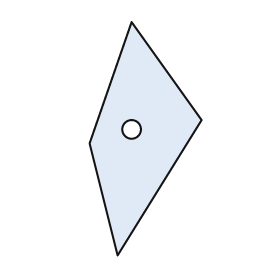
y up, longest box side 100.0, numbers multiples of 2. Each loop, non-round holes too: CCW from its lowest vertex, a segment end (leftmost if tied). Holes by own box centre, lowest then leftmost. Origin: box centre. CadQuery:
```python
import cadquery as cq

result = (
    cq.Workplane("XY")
    .moveTo(-12.0, -50.0)
    .lineTo(24.0, 8.0)
    .lineTo(-6.0, 50.0)
    .lineTo(-24.0, -2.0)
    .close()
    .moveTo(-6.0, 4.0)
    .circle(4.0)
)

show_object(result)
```